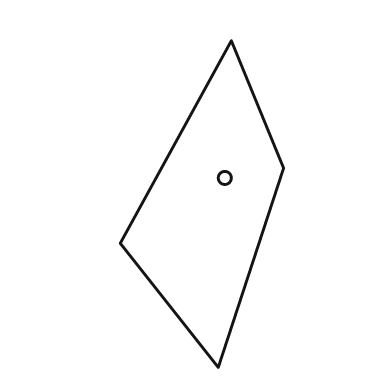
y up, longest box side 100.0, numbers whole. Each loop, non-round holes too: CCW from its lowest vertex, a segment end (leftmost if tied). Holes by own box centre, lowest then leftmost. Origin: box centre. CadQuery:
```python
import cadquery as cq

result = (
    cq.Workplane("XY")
    .moveTo(5.0, -50.0)
    .lineTo(25.0, 11.0)
    .lineTo(9.0, 50.0)
    .lineTo(-25.0, -12.0)
    .close()
    .moveTo(7.0, 8.0)
    .circle(2.0)
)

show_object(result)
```